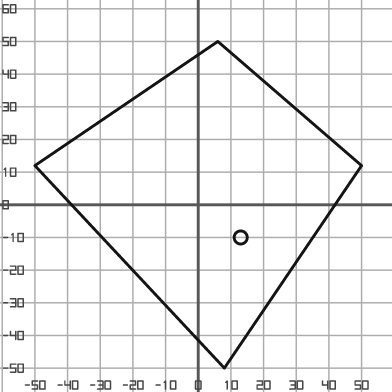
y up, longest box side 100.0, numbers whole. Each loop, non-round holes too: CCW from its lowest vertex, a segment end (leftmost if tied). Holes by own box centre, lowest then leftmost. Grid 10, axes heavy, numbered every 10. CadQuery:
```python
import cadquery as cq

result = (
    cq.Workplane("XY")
    .moveTo(8.0, -50.0)
    .lineTo(50.0, 12.0)
    .lineTo(6.0, 50.0)
    .lineTo(-50.0, 12.0)
    .close()
    .moveTo(13.0, -10.0)
    .circle(2.0)
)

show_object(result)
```